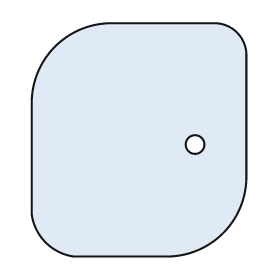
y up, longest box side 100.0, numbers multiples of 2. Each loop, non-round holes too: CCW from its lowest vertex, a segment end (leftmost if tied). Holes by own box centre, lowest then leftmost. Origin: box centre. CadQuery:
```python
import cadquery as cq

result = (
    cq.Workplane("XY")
    .moveTo(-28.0, -50.0)
    .lineTo(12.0, -50.0)
    .threePointArc((36.0, -40.0), (46.0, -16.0))
    .lineTo(46.0, 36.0)
    .threePointArc((42.0, 46.0), (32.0, 50.0))
    .lineTo(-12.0, 50.0)
    .threePointArc((-36.0, 40.0), (-46.0, 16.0))
    .lineTo(-46.0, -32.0)
    .threePointArc((-40.0, -44.0), (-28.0, -50.0))
    .close()
    .moveTo(24.0, -2.0)
    .circle(4.0)
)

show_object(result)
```